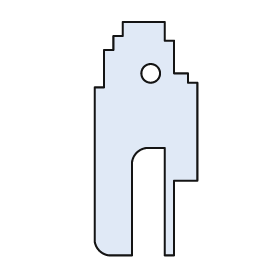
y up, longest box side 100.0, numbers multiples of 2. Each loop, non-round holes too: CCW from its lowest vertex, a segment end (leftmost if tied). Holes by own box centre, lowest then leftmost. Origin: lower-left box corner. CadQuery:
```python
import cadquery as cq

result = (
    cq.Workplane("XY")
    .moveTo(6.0, 0.0)
    .lineTo(16.0, 0.0)
    .lineTo(16.0, 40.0)
    .threePointArc((18.0, 44.0), (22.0, 46.0))
    .lineTo(30.0, 46.0)
    .lineTo(30.0, 0.0)
    .lineTo(34.0, 0.0)
    .lineTo(34.0, 32.0)
    .lineTo(44.0, 32.0)
    .lineTo(44.0, 74.0)
    .lineTo(40.0, 74.0)
    .lineTo(40.0, 78.0)
    .lineTo(34.0, 78.0)
    .lineTo(34.0, 92.0)
    .lineTo(30.0, 92.0)
    .lineTo(30.0, 100.0)
    .lineTo(12.0, 100.0)
    .lineTo(12.0, 94.0)
    .lineTo(8.0, 94.0)
    .lineTo(8.0, 88.0)
    .lineTo(4.0, 88.0)
    .lineTo(4.0, 72.0)
    .lineTo(0.0, 72.0)
    .lineTo(0.0, 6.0)
    .threePointArc((2.0, 2.0), (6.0, 0.0))
    .close()
    .moveTo(24.0, 78.0)
    .circle(4.0)
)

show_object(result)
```